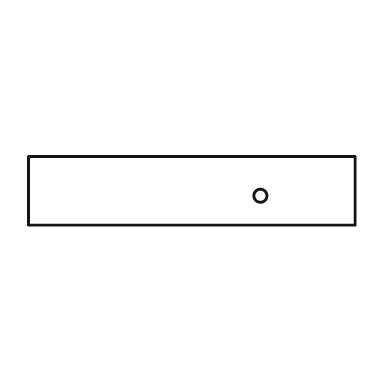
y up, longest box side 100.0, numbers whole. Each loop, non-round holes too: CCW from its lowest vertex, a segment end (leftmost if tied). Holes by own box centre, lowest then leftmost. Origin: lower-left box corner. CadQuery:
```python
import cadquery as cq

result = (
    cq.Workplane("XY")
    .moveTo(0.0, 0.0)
    .lineTo(100.0, 0.0)
    .lineTo(100.0, 21.0)
    .lineTo(0.0, 21.0)
    .close()
    .moveTo(71.0, 9.0)
    .circle(2.0)
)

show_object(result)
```